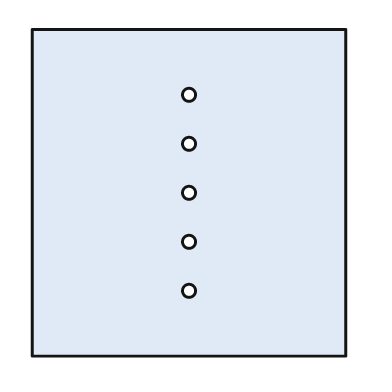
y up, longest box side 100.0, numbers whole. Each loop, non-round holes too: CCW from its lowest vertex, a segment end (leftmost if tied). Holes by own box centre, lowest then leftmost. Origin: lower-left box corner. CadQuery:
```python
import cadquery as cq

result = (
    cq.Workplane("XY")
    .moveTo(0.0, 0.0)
    .lineTo(96.0, 0.0)
    .lineTo(96.0, 100.0)
    .lineTo(0.0, 100.0)
    .close()
    .moveTo(48.0, 20.0)
    .circle(2.0)
    .moveTo(48.0, 35.0)
    .circle(2.0)
    .moveTo(48.0, 50.0)
    .circle(2.0)
    .moveTo(48.0, 65.0)
    .circle(2.0)
    .moveTo(48.0, 80.0)
    .circle(2.0)
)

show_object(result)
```